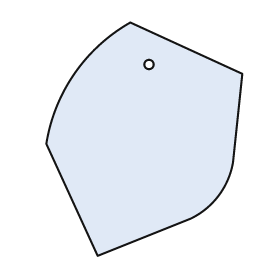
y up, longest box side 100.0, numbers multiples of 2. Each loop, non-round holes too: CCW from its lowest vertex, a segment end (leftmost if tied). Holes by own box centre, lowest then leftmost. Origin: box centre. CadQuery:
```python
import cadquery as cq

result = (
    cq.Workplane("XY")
    .moveTo(-20.0, -50.0)
    .lineTo(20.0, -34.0)
    .threePointArc((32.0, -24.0), (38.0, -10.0))
    .lineTo(42.0, 28.0)
    .lineTo(-6.0, 50.0)
    .threePointArc((-30.0, 28.0), (-42.0, -2.0))
    .close()
    .moveTo(2.0, 32.0)
    .circle(2.0)
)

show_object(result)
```